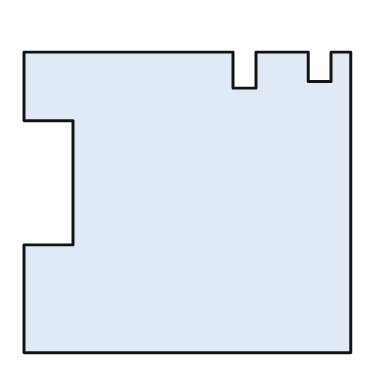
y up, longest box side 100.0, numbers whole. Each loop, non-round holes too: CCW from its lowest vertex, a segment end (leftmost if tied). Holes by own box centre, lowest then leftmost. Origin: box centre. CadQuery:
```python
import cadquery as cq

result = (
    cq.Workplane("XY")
    .moveTo(-50.0, -46.0)
    .lineTo(50.0, -46.0)
    .lineTo(50.0, 46.0)
    .lineTo(44.0, 46.0)
    .lineTo(44.0, 37.0)
    .lineTo(37.0, 37.0)
    .lineTo(37.0, 46.0)
    .lineTo(21.0, 46.0)
    .lineTo(21.0, 35.0)
    .lineTo(14.0, 35.0)
    .lineTo(14.0, 46.0)
    .lineTo(-50.0, 46.0)
    .lineTo(-50.0, 25.0)
    .lineTo(-35.0, 25.0)
    .lineTo(-35.0, -13.0)
    .lineTo(-50.0, -13.0)
    .close()
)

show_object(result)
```